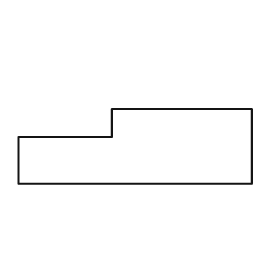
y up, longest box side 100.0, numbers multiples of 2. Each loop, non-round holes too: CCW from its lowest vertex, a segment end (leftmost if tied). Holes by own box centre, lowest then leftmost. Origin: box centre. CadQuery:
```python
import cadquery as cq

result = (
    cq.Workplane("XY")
    .moveTo(-50.0, -16.0)
    .lineTo(50.0, -16.0)
    .lineTo(50.0, 16.0)
    .lineTo(-10.0, 16.0)
    .lineTo(-10.0, 4.0)
    .lineTo(-50.0, 4.0)
    .close()
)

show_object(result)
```